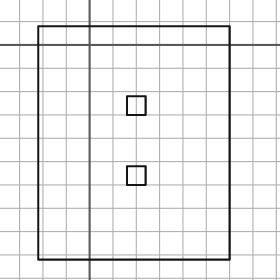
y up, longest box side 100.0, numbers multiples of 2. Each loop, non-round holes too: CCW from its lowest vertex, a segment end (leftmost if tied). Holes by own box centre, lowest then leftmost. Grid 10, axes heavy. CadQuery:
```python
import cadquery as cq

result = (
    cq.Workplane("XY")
    .moveTo(-22.0, -92.0)
    .lineTo(60.0, -92.0)
    .lineTo(60.0, 8.0)
    .lineTo(-22.0, 8.0)
    .close()
    .moveTo(16.0, -60.0)
    .lineTo(24.0, -60.0)
    .lineTo(24.0, -52.0)
    .lineTo(16.0, -52.0)
    .close()
    .moveTo(16.0, -30.0)
    .lineTo(24.0, -30.0)
    .lineTo(24.0, -22.0)
    .lineTo(16.0, -22.0)
    .close()
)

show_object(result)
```